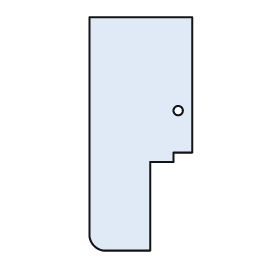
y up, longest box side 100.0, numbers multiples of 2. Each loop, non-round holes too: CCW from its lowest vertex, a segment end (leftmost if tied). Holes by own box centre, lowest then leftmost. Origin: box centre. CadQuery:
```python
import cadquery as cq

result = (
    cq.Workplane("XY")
    .moveTo(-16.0, -50.0)
    .lineTo(4.0, -50.0)
    .lineTo(4.0, -12.0)
    .lineTo(14.0, -12.0)
    .lineTo(14.0, -8.0)
    .lineTo(22.0, -8.0)
    .lineTo(22.0, 50.0)
    .lineTo(-22.0, 50.0)
    .lineTo(-22.0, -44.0)
    .threePointArc((-20.0, -48.0), (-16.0, -50.0))
    .close()
    .moveTo(16.0, 10.0)
    .circle(2.0)
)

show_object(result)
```